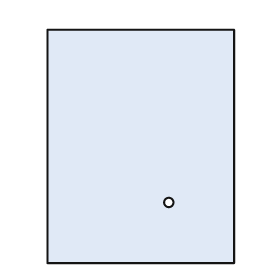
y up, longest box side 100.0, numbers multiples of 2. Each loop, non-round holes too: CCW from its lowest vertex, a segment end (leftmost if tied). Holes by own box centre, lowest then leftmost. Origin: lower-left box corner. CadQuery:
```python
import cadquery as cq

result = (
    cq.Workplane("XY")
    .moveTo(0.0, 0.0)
    .lineTo(80.0, 0.0)
    .lineTo(80.0, 100.0)
    .lineTo(0.0, 100.0)
    .close()
    .moveTo(52.0, 26.0)
    .circle(2.0)
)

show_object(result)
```